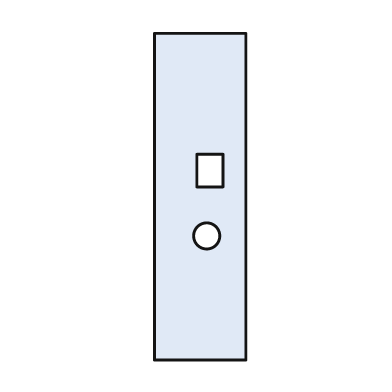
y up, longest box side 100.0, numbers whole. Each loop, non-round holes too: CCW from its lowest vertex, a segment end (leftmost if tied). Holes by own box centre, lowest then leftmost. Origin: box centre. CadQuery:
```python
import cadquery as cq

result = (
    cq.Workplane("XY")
    .moveTo(-14.0, -50.0)
    .lineTo(14.0, -50.0)
    .lineTo(14.0, 50.0)
    .lineTo(-14.0, 50.0)
    .close()
    .moveTo(2.0, -12.0)
    .circle(4.0)
    .moveTo(-1.0, 3.0)
    .lineTo(7.0, 3.0)
    .lineTo(7.0, 13.0)
    .lineTo(-1.0, 13.0)
    .close()
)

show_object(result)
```